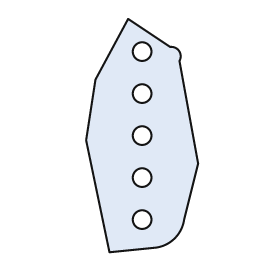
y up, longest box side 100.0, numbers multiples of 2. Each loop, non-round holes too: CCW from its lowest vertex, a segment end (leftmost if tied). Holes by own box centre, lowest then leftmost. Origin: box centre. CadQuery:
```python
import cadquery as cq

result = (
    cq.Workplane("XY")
    .moveTo(-14.0, -50.0)
    .lineTo(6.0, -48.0)
    .threePointArc((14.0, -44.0), (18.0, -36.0))
    .lineTo(24.0, -12.0)
    .lineTo(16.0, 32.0)
    .threePointArc((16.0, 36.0), (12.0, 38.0))
    .lineTo(-6.0, 50.0)
    .lineTo(-20.0, 24.0)
    .lineTo(-24.0, -2.0)
    .close()
    .moveTo(0.0, -36.0)
    .circle(4.0)
    .moveTo(0.0, -18.0)
    .circle(4.0)
    .moveTo(0.0, 0.0)
    .circle(4.0)
    .moveTo(0.0, 18.0)
    .circle(4.0)
    .moveTo(0.0, 36.0)
    .circle(4.0)
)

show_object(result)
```